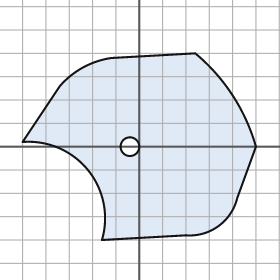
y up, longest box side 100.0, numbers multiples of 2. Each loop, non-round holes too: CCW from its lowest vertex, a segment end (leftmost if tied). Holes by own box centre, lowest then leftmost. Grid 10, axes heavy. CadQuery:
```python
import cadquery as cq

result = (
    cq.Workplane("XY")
    .moveTo(-16.0, -40.0)
    .lineTo(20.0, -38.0)
    .threePointArc((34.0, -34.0), (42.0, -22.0))
    .lineTo(50.0, 0.0)
    .threePointArc((40.0, 22.0), (24.0, 40.0))
    .lineTo(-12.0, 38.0)
    .threePointArc((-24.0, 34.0), (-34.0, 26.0))
    .lineTo(-50.0, 2.0)
    .threePointArc((-22.0, -10.0), (-16.0, -40.0))
    .close()
    .moveTo(-4.0, 0.0)
    .circle(4.0)
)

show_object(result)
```